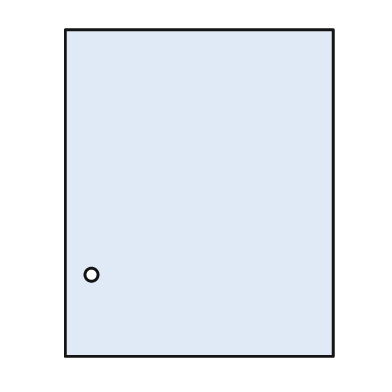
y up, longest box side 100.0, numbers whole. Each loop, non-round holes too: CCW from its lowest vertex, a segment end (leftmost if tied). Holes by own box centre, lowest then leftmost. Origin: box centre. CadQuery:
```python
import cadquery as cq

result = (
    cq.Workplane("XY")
    .moveTo(-41.0, -50.0)
    .lineTo(41.0, -50.0)
    .lineTo(41.0, 50.0)
    .lineTo(-41.0, 50.0)
    .close()
    .moveTo(-33.0, -25.0)
    .circle(2.0)
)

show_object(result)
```